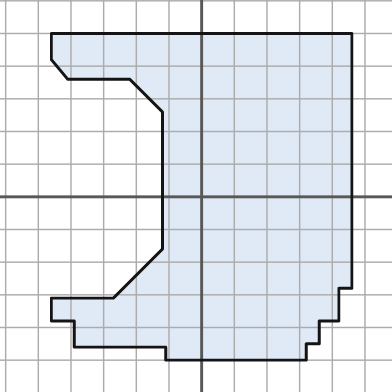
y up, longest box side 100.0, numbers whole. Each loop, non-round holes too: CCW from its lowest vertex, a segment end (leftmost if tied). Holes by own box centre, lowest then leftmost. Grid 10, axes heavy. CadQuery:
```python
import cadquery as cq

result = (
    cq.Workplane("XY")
    .moveTo(-11.0, -50.0)
    .lineTo(32.0, -50.0)
    .lineTo(32.0, -45.0)
    .lineTo(36.0, -45.0)
    .lineTo(36.0, -38.0)
    .lineTo(42.0, -38.0)
    .lineTo(42.0, -28.0)
    .lineTo(46.0, -28.0)
    .lineTo(46.0, 50.0)
    .lineTo(-46.0, 50.0)
    .lineTo(-46.0, 42.0)
    .lineTo(-41.0, 36.0)
    .lineTo(-22.0, 36.0)
    .lineTo(-12.0, 26.0)
    .lineTo(-12.0, -16.0)
    .lineTo(-27.0, -31.0)
    .lineTo(-46.0, -31.0)
    .lineTo(-46.0, -38.0)
    .lineTo(-39.0, -38.0)
    .lineTo(-39.0, -46.0)
    .lineTo(-11.0, -46.0)
    .close()
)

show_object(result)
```